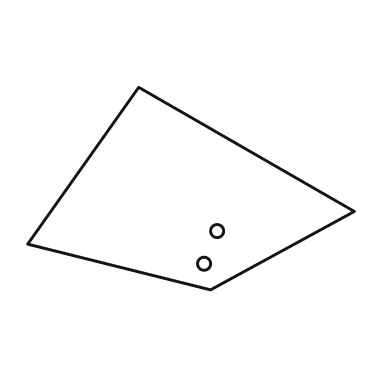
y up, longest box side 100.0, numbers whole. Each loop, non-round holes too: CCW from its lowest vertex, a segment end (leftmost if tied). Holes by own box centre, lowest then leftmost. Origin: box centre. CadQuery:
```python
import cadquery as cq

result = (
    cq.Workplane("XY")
    .moveTo(6.0, -31.0)
    .lineTo(50.0, -7.0)
    .lineTo(-16.0, 31.0)
    .lineTo(-50.0, -17.0)
    .close()
    .moveTo(4.0, -23.0)
    .circle(2.0)
    .moveTo(8.0, -13.0)
    .circle(2.0)
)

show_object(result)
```